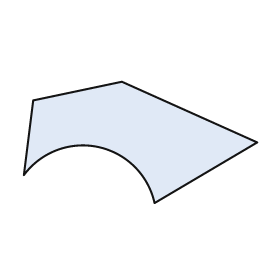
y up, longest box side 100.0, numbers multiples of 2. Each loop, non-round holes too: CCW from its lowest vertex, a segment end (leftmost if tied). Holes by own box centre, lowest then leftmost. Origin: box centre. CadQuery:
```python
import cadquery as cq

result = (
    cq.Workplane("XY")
    .moveTo(6.0, -26.0)
    .lineTo(50.0, 0.0)
    .lineTo(-8.0, 26.0)
    .lineTo(-46.0, 18.0)
    .lineTo(-50.0, -14.0)
    .threePointArc((-18.0, -2.0), (6.0, -26.0))
    .close()
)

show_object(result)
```